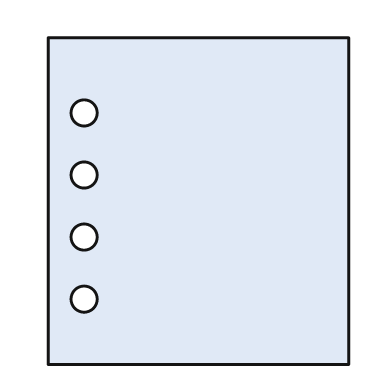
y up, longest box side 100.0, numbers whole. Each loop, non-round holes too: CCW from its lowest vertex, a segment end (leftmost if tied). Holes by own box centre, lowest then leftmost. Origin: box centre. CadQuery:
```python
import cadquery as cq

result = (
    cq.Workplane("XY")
    .moveTo(-46.0, -50.0)
    .lineTo(46.0, -50.0)
    .lineTo(46.0, 50.0)
    .lineTo(-46.0, 50.0)
    .close()
    .moveTo(-35.0, -30.0)
    .circle(4.0)
    .moveTo(-35.0, -11.0)
    .circle(4.0)
    .moveTo(-35.0, 8.0)
    .circle(4.0)
    .moveTo(-35.0, 27.0)
    .circle(4.0)
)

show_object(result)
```